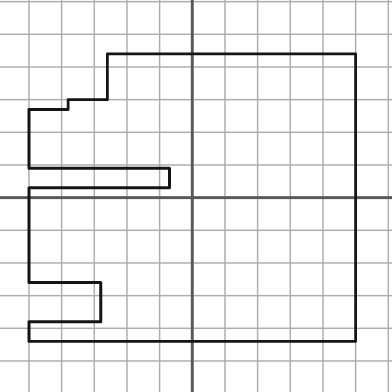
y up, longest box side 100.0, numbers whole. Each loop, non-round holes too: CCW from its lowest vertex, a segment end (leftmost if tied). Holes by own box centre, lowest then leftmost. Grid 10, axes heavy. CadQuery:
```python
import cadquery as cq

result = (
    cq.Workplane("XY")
    .moveTo(-50.0, -44.0)
    .lineTo(50.0, -44.0)
    .lineTo(50.0, 44.0)
    .lineTo(-26.0, 44.0)
    .lineTo(-26.0, 30.0)
    .lineTo(-38.0, 30.0)
    .lineTo(-38.0, 27.0)
    .lineTo(-50.0, 27.0)
    .lineTo(-50.0, 9.0)
    .lineTo(-7.0, 9.0)
    .lineTo(-7.0, 3.0)
    .lineTo(-50.0, 3.0)
    .lineTo(-50.0, -26.0)
    .lineTo(-28.0, -26.0)
    .lineTo(-28.0, -38.0)
    .lineTo(-50.0, -38.0)
    .close()
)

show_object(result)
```